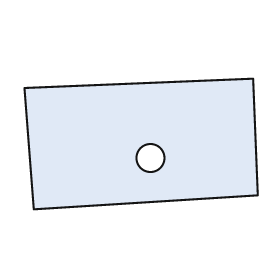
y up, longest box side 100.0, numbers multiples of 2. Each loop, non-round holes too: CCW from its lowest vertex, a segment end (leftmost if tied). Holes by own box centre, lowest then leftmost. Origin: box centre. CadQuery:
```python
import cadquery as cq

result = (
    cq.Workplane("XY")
    .moveTo(-46.0, -28.0)
    .lineTo(50.0, -22.0)
    .lineTo(48.0, 28.0)
    .lineTo(-50.0, 24.0)
    .close()
    .moveTo(4.0, -6.0)
    .circle(6.0)
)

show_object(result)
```